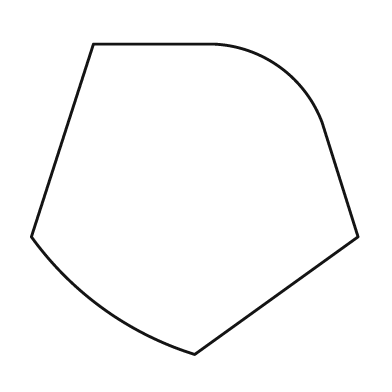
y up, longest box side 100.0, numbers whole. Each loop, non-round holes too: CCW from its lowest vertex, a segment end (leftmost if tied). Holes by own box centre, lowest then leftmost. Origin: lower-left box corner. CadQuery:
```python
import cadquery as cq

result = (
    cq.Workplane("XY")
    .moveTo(50.0, 0.0)
    .lineTo(100.0, 36.0)
    .lineTo(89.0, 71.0)
    .threePointArc((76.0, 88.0), (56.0, 95.0))
    .lineTo(19.0, 95.0)
    .lineTo(0.0, 36.0)
    .threePointArc((22.0, 14.0), (50.0, 0.0))
    .close()
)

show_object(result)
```